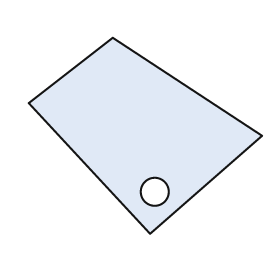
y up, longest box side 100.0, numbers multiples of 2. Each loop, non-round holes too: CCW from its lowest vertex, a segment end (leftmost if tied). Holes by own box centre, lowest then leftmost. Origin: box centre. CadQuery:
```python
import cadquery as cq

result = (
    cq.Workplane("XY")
    .moveTo(2.0, -42.0)
    .lineTo(50.0, 0.0)
    .lineTo(-14.0, 42.0)
    .lineTo(-50.0, 14.0)
    .close()
    .moveTo(4.0, -24.0)
    .circle(6.0)
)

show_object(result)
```